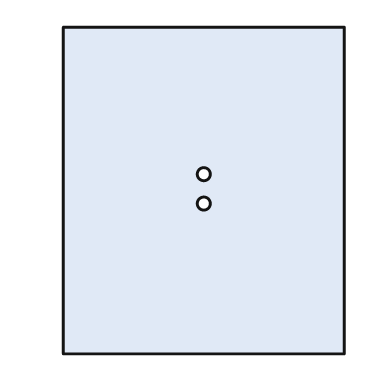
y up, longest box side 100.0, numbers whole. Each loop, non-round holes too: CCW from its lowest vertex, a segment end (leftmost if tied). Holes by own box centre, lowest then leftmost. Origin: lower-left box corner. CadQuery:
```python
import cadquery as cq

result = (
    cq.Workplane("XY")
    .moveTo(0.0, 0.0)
    .lineTo(86.0, 0.0)
    .lineTo(86.0, 100.0)
    .lineTo(0.0, 100.0)
    .close()
    .moveTo(43.0, 46.0)
    .circle(2.0)
    .moveTo(43.0, 55.0)
    .circle(2.0)
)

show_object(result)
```